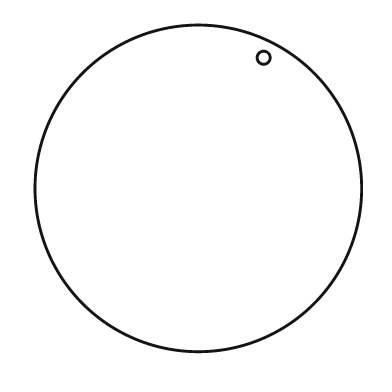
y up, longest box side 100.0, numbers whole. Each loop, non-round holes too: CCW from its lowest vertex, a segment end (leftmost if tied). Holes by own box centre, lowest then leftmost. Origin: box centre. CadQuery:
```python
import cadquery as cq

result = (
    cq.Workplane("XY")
    .moveTo(0.0, 0.0)
    .circle(50.0)
    .moveTo(20.0, 40.0)
    .circle(2.0)
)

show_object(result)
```